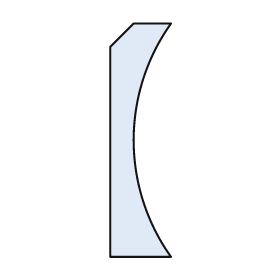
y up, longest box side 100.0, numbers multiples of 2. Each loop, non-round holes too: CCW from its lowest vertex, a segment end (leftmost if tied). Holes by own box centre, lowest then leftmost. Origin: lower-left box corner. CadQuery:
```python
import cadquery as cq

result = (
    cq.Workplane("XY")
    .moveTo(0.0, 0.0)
    .lineTo(26.0, 0.0)
    .threePointArc((10.0, 50.0), (26.0, 100.0))
    .lineTo(10.0, 100.0)
    .lineTo(0.0, 90.0)
    .close()
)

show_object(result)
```